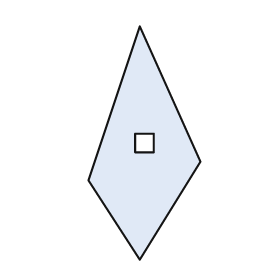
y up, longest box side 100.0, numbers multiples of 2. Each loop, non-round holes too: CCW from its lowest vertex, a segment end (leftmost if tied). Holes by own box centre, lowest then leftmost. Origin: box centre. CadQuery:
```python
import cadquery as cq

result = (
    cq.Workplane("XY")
    .moveTo(-2.0, -50.0)
    .lineTo(24.0, -8.0)
    .lineTo(-2.0, 50.0)
    .lineTo(-24.0, -16.0)
    .close()
    .moveTo(-4.0, -4.0)
    .lineTo(4.0, -4.0)
    .lineTo(4.0, 4.0)
    .lineTo(-4.0, 4.0)
    .close()
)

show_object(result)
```